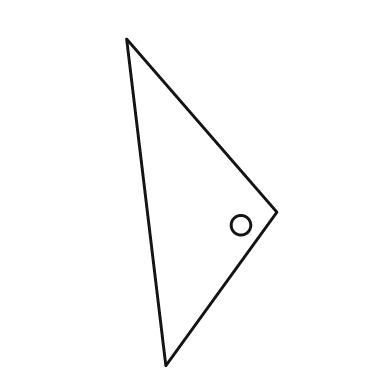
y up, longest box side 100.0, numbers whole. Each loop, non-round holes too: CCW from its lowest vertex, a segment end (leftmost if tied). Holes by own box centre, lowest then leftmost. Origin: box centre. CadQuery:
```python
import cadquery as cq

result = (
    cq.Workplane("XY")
    .moveTo(-11.0, -50.0)
    .lineTo(23.0, -3.0)
    .lineTo(-23.0, 50.0)
    .close()
    .moveTo(12.0, -7.0)
    .circle(3.0)
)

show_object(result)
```